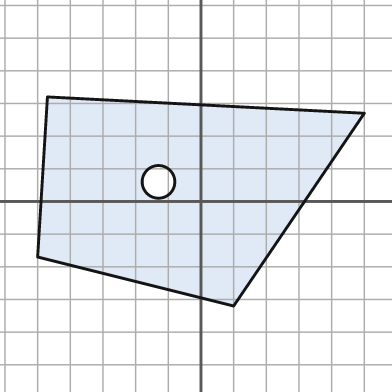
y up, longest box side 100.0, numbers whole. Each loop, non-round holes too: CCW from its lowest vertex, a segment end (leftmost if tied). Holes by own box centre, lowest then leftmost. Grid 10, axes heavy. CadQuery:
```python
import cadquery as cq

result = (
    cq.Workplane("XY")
    .moveTo(10.0, -32.0)
    .lineTo(50.0, 27.0)
    .lineTo(-47.0, 32.0)
    .lineTo(-50.0, -17.0)
    .close()
    .moveTo(-13.0, 6.0)
    .circle(5.0)
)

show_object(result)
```